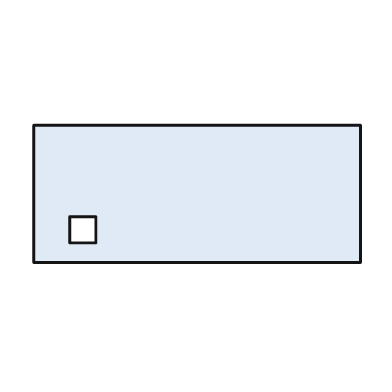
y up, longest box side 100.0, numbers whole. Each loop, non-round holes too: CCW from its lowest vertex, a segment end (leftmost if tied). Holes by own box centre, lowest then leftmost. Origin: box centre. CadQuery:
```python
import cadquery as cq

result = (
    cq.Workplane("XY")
    .moveTo(-50.0, -21.0)
    .lineTo(50.0, -21.0)
    .lineTo(50.0, 21.0)
    .lineTo(-50.0, 21.0)
    .close()
    .moveTo(-39.0, -15.0)
    .lineTo(-31.0, -15.0)
    .lineTo(-31.0, -7.0)
    .lineTo(-39.0, -7.0)
    .close()
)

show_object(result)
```